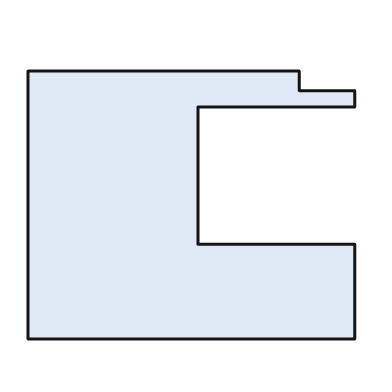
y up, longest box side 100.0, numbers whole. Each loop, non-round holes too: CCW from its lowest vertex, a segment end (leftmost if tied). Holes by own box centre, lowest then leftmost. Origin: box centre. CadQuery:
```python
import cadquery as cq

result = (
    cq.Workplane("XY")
    .moveTo(-50.0, -41.0)
    .lineTo(50.0, -41.0)
    .lineTo(50.0, -12.0)
    .lineTo(2.0, -12.0)
    .lineTo(2.0, 30.0)
    .lineTo(50.0, 30.0)
    .lineTo(50.0, 35.0)
    .lineTo(33.0, 35.0)
    .lineTo(33.0, 41.0)
    .lineTo(-50.0, 41.0)
    .close()
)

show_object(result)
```